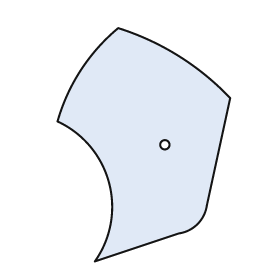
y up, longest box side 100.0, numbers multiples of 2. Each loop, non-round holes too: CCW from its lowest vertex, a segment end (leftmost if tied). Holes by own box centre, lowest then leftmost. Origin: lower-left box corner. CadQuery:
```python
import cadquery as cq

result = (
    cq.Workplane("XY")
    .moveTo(16.0, 0.0)
    .lineTo(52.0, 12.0)
    .threePointArc((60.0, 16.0), (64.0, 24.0))
    .lineTo(74.0, 70.0)
    .threePointArc((52.0, 88.0), (26.0, 100.0))
    .threePointArc((10.0, 82.0), (0.0, 60.0))
    .threePointArc((22.0, 34.0), (16.0, 0.0))
    .close()
    .moveTo(46.0, 50.0)
    .circle(2.0)
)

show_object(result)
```